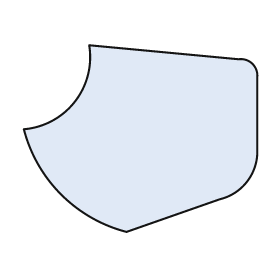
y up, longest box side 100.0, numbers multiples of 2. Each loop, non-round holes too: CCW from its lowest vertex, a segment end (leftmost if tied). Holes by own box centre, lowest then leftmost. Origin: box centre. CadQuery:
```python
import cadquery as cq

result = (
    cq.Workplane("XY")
    .moveTo(-6.0, -40.0)
    .lineTo(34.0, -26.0)
    .threePointArc((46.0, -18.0), (50.0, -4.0))
    .lineTo(50.0, 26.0)
    .threePointArc((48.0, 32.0), (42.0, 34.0))
    .lineTo(-22.0, 40.0)
    .threePointArc((-28.0, 16.0), (-50.0, 4.0))
    .threePointArc((-34.0, -24.0), (-6.0, -40.0))
    .close()
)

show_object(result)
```